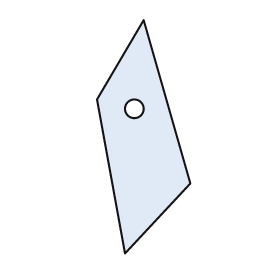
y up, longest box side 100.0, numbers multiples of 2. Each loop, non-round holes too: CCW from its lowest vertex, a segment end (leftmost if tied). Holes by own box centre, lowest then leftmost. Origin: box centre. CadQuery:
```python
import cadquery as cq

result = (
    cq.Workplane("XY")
    .moveTo(-8.0, -50.0)
    .lineTo(20.0, -20.0)
    .lineTo(0.0, 50.0)
    .lineTo(-20.0, 16.0)
    .close()
    .moveTo(-4.0, 12.0)
    .circle(4.0)
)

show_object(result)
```